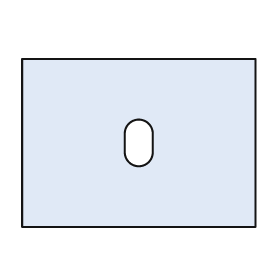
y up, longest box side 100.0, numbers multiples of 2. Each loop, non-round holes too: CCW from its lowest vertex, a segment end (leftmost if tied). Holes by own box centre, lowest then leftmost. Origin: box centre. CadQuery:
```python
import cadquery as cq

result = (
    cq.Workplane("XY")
    .moveTo(-50.0, -36.0)
    .lineTo(50.0, -36.0)
    .lineTo(50.0, 36.0)
    .lineTo(-50.0, 36.0)
    .close()
    .moveTo(-6.0, -4.0)
    .threePointArc((0.0, -10.0), (6.0, -4.0))
    .lineTo(6.0, 4.0)
    .threePointArc((0.0, 10.0), (-6.0, 4.0))
    .close()
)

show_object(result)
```